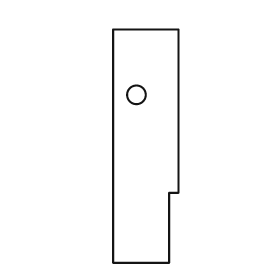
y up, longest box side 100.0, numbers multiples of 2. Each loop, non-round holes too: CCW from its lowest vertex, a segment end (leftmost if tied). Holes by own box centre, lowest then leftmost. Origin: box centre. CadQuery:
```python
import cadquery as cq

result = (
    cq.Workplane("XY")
    .moveTo(-14.0, -50.0)
    .lineTo(10.0, -50.0)
    .lineTo(10.0, -20.0)
    .lineTo(14.0, -20.0)
    .lineTo(14.0, 50.0)
    .lineTo(-14.0, 50.0)
    .close()
    .moveTo(-4.0, 22.0)
    .circle(4.0)
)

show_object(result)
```